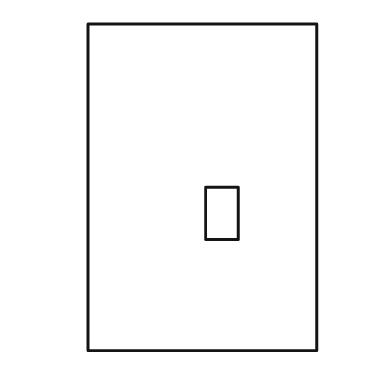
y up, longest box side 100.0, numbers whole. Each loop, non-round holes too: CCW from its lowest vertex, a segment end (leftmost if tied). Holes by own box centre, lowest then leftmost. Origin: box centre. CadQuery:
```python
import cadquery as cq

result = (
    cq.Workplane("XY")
    .moveTo(-35.0, -50.0)
    .lineTo(35.0, -50.0)
    .lineTo(35.0, 50.0)
    .lineTo(-35.0, 50.0)
    .close()
    .moveTo(1.0, -16.0)
    .lineTo(11.0, -16.0)
    .lineTo(11.0, 0.0)
    .lineTo(1.0, 0.0)
    .close()
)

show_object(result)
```